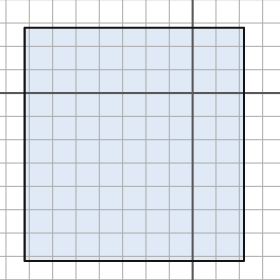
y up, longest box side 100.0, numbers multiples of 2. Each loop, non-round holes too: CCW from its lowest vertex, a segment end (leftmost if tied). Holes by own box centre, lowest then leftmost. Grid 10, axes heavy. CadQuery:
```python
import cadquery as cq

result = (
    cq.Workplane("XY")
    .moveTo(-72.0, -72.0)
    .lineTo(22.0, -72.0)
    .lineTo(22.0, 28.0)
    .lineTo(-72.0, 28.0)
    .close()
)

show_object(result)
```